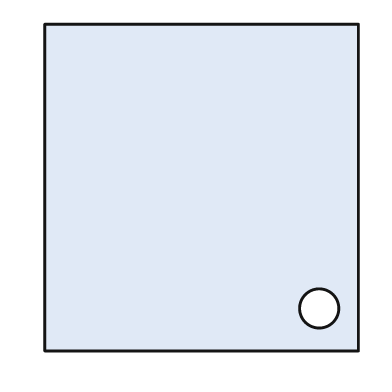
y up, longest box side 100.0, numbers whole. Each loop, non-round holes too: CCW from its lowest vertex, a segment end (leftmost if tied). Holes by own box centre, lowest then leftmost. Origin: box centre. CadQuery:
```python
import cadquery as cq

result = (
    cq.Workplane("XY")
    .moveTo(-48.0, -50.0)
    .lineTo(48.0, -50.0)
    .lineTo(48.0, 50.0)
    .lineTo(-48.0, 50.0)
    .close()
    .moveTo(36.0, -37.0)
    .circle(6.0)
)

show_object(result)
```